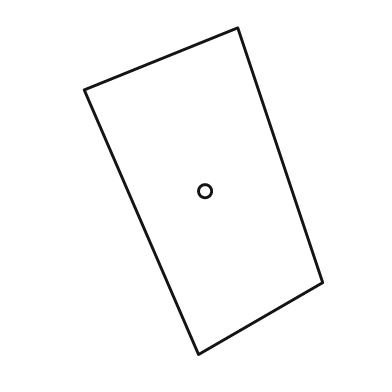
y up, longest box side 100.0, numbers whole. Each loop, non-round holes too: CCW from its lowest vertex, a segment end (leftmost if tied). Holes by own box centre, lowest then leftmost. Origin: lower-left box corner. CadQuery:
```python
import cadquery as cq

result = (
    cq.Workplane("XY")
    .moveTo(35.0, 0.0)
    .lineTo(73.0, 22.0)
    .lineTo(47.0, 100.0)
    .lineTo(0.0, 81.0)
    .close()
    .moveTo(37.0, 50.0)
    .circle(2.0)
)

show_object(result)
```